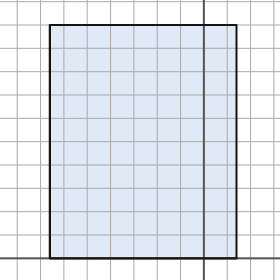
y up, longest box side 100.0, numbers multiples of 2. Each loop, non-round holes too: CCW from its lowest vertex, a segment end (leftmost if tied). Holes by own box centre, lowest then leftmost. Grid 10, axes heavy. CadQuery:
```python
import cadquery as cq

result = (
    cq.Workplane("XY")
    .moveTo(-66.0, 0.0)
    .lineTo(14.0, 0.0)
    .lineTo(14.0, 100.0)
    .lineTo(-66.0, 100.0)
    .close()
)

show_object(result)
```